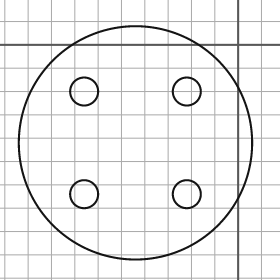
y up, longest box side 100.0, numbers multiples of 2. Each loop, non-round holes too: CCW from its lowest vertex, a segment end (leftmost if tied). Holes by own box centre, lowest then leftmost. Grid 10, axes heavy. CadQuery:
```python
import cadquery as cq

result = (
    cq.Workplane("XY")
    .moveTo(-44.0, -42.0)
    .circle(50.0)
    .moveTo(-66.0, -64.0)
    .circle(6.0)
    .moveTo(-22.0, -64.0)
    .circle(6.0)
    .moveTo(-66.0, -20.0)
    .circle(6.0)
    .moveTo(-22.0, -20.0)
    .circle(6.0)
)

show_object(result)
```